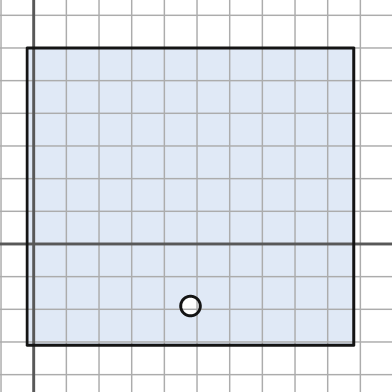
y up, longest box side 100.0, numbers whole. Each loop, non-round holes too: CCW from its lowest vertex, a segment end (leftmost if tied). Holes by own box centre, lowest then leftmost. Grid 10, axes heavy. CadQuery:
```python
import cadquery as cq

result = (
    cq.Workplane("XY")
    .moveTo(-2.0, -31.0)
    .lineTo(98.0, -31.0)
    .lineTo(98.0, 60.0)
    .lineTo(-2.0, 60.0)
    .close()
    .moveTo(48.0, -19.0)
    .circle(3.0)
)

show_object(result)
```